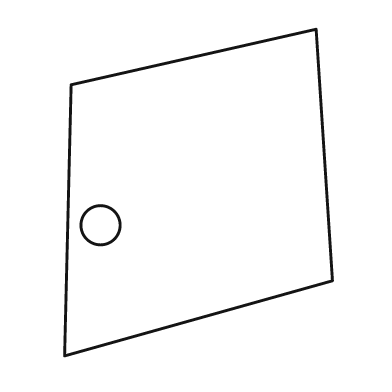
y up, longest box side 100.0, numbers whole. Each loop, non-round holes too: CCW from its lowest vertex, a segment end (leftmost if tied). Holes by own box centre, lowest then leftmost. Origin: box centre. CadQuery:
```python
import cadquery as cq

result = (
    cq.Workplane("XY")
    .moveTo(-41.0, -50.0)
    .lineTo(41.0, -27.0)
    .lineTo(36.0, 50.0)
    .lineTo(-39.0, 33.0)
    .close()
    .moveTo(-30.0, -10.0)
    .circle(6.0)
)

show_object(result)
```